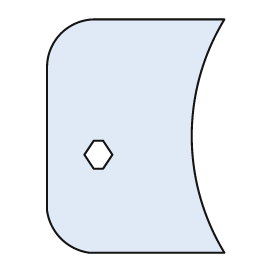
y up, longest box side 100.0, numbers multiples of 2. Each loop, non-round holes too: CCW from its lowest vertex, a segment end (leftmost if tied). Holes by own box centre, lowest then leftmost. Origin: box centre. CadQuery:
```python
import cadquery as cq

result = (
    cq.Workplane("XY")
    .moveTo(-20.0, -50.0)
    .lineTo(38.0, -50.0)
    .threePointArc((24.0, 0.0), (38.0, 50.0))
    .lineTo(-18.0, 50.0)
    .threePointArc((-32.0, 44.0), (-38.0, 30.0))
    .lineTo(-38.0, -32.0)
    .threePointArc((-32.0, -44.0), (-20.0, -50.0))
    .close()
    .moveTo(-18.0, -14.0)
    .lineTo(-14.0, -14.0)
    .lineTo(-10.0, -8.0)
    .lineTo(-14.0, -2.0)
    .lineTo(-18.0, -2.0)
    .lineTo(-22.0, -8.0)
    .close()
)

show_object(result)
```